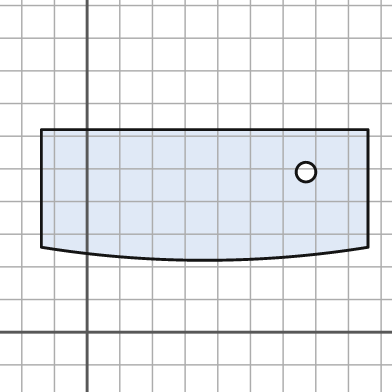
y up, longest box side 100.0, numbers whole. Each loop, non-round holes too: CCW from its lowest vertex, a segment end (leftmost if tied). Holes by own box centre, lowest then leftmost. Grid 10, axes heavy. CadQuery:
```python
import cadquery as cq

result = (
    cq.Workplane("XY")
    .moveTo(-14.0, 26.0)
    .threePointArc((36.0, 22.0), (86.0, 26.0))
    .lineTo(86.0, 62.0)
    .lineTo(-14.0, 62.0)
    .close()
    .moveTo(67.0, 49.0)
    .circle(3.0)
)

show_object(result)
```